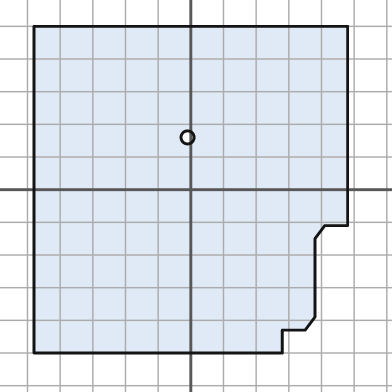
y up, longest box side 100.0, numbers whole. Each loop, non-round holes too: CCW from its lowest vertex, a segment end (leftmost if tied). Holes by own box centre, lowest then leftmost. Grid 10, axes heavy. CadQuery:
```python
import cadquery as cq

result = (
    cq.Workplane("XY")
    .moveTo(-48.0, -50.0)
    .lineTo(28.0, -50.0)
    .lineTo(28.0, -43.0)
    .lineTo(35.0, -43.0)
    .lineTo(38.0, -39.0)
    .lineTo(38.0, -15.0)
    .lineTo(41.0, -11.0)
    .lineTo(48.0, -11.0)
    .lineTo(48.0, 50.0)
    .lineTo(-48.0, 50.0)
    .close()
    .moveTo(-1.0, 16.0)
    .circle(2.0)
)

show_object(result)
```